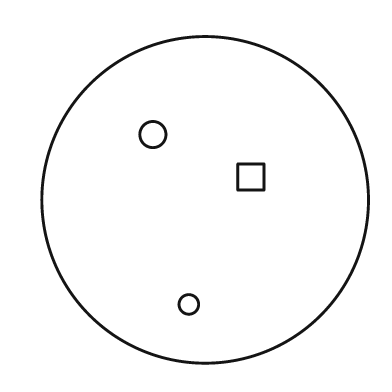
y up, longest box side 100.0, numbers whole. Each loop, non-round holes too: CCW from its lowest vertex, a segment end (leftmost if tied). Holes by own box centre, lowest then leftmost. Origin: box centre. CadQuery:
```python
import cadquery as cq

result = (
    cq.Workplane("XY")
    .moveTo(0.0, 0.0)
    .circle(50.0)
    .moveTo(-5.0, -32.0)
    .circle(3.0)
    .moveTo(10.0, 3.0)
    .lineTo(18.0, 3.0)
    .lineTo(18.0, 11.0)
    .lineTo(10.0, 11.0)
    .close()
    .moveTo(-16.0, 20.0)
    .circle(4.0)
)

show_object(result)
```